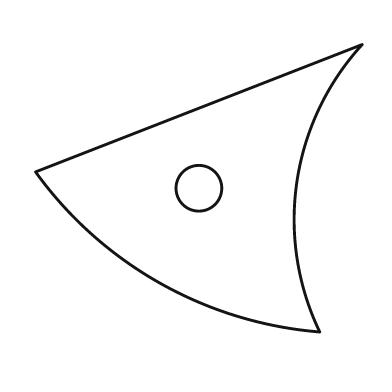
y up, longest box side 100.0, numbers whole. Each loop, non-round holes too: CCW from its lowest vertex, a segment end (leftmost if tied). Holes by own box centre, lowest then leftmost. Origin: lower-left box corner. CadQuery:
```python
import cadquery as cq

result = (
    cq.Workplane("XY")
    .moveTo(87.0, 0.0)
    .threePointArc((80.0, 46.0), (100.0, 88.0))
    .lineTo(0.0, 49.0)
    .threePointArc((38.0, 15.0), (87.0, 0.0))
    .close()
    .moveTo(50.0, 44.0)
    .circle(7.0)
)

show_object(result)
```